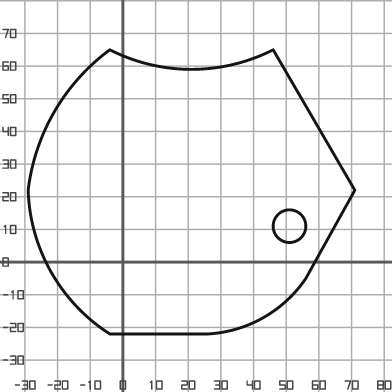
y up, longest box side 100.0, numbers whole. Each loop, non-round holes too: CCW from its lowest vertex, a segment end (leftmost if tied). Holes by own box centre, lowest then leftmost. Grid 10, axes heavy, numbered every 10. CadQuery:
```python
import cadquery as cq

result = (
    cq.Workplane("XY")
    .moveTo(-4.0, -22.0)
    .lineTo(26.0, -22.0)
    .threePointArc((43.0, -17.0), (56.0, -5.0))
    .lineTo(71.0, 22.0)
    .lineTo(46.0, 65.0)
    .threePointArc((21.0, 59.0), (-4.0, 65.0))
    .threePointArc((-21.0, 46.0), (-29.0, 22.0))
    .threePointArc((-22.0, -3.0), (-4.0, -22.0))
    .close()
    .moveTo(51.0, 11.0)
    .circle(5.0)
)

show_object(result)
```